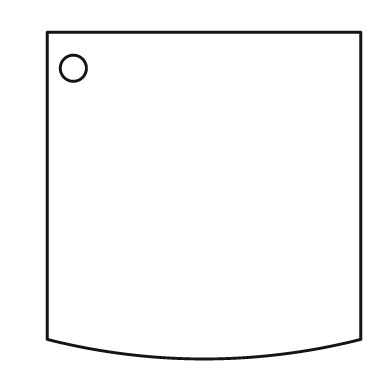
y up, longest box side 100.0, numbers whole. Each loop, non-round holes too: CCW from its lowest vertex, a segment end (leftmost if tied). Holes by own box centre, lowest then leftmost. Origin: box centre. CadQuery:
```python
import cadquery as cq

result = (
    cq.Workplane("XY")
    .moveTo(-48.0, -44.0)
    .threePointArc((0.0, -50.0), (48.0, -44.0))
    .lineTo(48.0, 50.0)
    .lineTo(-48.0, 50.0)
    .close()
    .moveTo(-40.0, 39.0)
    .circle(4.0)
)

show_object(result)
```